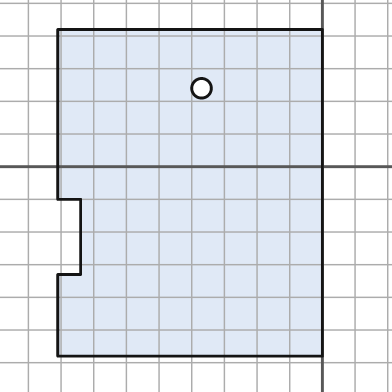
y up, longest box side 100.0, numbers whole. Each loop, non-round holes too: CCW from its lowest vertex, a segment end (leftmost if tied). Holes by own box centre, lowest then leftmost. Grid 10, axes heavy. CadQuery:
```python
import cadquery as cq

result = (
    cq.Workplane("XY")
    .moveTo(-81.0, -58.0)
    .lineTo(0.0, -58.0)
    .lineTo(0.0, 42.0)
    .lineTo(-81.0, 42.0)
    .lineTo(-81.0, -10.0)
    .lineTo(-74.0, -10.0)
    .lineTo(-74.0, -33.0)
    .lineTo(-81.0, -33.0)
    .close()
    .moveTo(-37.0, 24.0)
    .circle(3.0)
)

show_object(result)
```